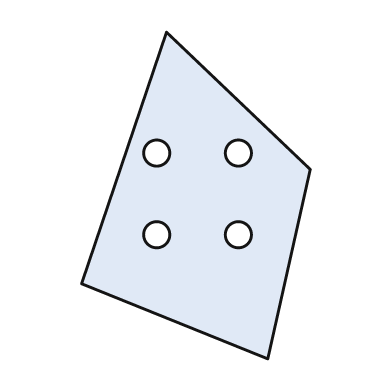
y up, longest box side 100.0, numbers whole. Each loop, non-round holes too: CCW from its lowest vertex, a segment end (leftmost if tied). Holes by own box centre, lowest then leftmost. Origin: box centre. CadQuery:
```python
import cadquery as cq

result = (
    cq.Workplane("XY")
    .moveTo(22.0, -50.0)
    .lineTo(35.0, 8.0)
    .lineTo(-9.0, 50.0)
    .lineTo(-35.0, -27.0)
    .close()
    .moveTo(-12.0, -12.0)
    .circle(4.0)
    .moveTo(13.0, -12.0)
    .circle(4.0)
    .moveTo(-12.0, 13.0)
    .circle(4.0)
    .moveTo(13.0, 13.0)
    .circle(4.0)
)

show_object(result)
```